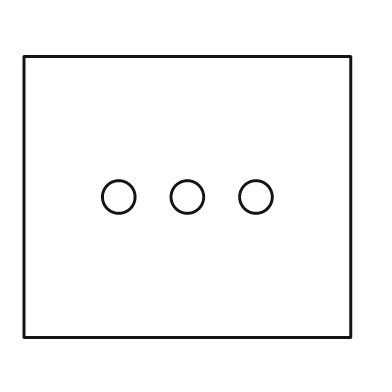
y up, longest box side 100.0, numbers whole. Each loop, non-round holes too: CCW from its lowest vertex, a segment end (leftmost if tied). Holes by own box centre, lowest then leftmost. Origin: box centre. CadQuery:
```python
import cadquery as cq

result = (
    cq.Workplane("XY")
    .moveTo(-50.0, -43.0)
    .lineTo(50.0, -43.0)
    .lineTo(50.0, 43.0)
    .lineTo(-50.0, 43.0)
    .close()
    .moveTo(-21.0, 0.0)
    .circle(5.0)
    .moveTo(0.0, 0.0)
    .circle(5.0)
    .moveTo(21.0, 0.0)
    .circle(5.0)
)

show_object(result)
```